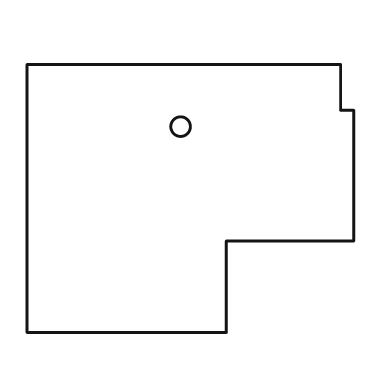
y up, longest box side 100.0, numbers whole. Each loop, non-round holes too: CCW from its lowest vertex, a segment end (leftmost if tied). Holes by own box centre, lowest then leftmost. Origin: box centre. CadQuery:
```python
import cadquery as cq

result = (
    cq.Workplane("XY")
    .moveTo(-50.0, -41.0)
    .lineTo(11.0, -41.0)
    .lineTo(11.0, -13.0)
    .lineTo(50.0, -13.0)
    .lineTo(50.0, 27.0)
    .lineTo(46.0, 27.0)
    .lineTo(46.0, 41.0)
    .lineTo(-50.0, 41.0)
    .close()
    .moveTo(-3.0, 22.0)
    .circle(3.0)
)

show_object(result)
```